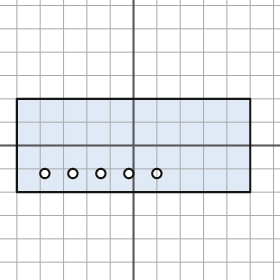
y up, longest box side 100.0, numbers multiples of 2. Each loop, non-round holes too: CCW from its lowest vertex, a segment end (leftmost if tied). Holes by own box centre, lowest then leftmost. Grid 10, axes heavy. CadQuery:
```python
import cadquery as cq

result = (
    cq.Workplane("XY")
    .moveTo(-50.0, -20.0)
    .lineTo(50.0, -20.0)
    .lineTo(50.0, 20.0)
    .lineTo(-50.0, 20.0)
    .close()
    .moveTo(-38.0, -12.0)
    .circle(2.0)
    .moveTo(-26.0, -12.0)
    .circle(2.0)
    .moveTo(-14.0, -12.0)
    .circle(2.0)
    .moveTo(-2.0, -12.0)
    .circle(2.0)
    .moveTo(10.0, -12.0)
    .circle(2.0)
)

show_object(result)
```